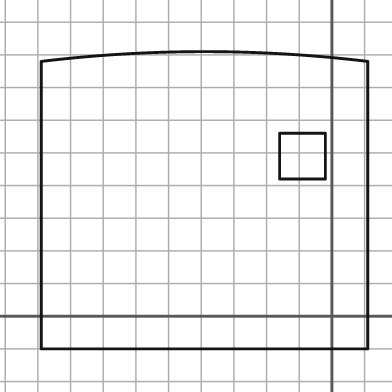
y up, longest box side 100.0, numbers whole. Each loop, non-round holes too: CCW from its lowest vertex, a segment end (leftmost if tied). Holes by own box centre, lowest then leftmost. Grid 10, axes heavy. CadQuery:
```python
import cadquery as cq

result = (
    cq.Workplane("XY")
    .moveTo(-89.0, -10.0)
    .lineTo(11.0, -10.0)
    .lineTo(11.0, 78.0)
    .threePointArc((-39.0, 81.0), (-89.0, 78.0))
    .close()
    .moveTo(-16.0, 42.0)
    .lineTo(-2.0, 42.0)
    .lineTo(-2.0, 56.0)
    .lineTo(-16.0, 56.0)
    .close()
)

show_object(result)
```